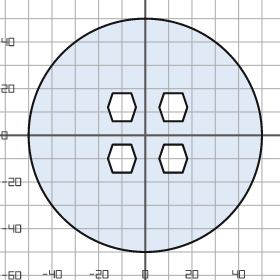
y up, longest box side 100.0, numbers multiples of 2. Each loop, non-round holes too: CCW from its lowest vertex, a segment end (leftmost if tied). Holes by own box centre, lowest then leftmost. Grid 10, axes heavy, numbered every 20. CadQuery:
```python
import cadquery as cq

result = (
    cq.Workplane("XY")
    .moveTo(0.0, 0.0)
    .circle(50.0)
    .moveTo(-14.0, -16.0)
    .lineTo(-6.0, -16.0)
    .lineTo(-4.0, -10.0)
    .lineTo(-6.0, -4.0)
    .lineTo(-14.0, -4.0)
    .lineTo(-16.0, -10.0)
    .close()
    .moveTo(8.0, -16.0)
    .lineTo(16.0, -16.0)
    .lineTo(18.0, -10.0)
    .lineTo(16.0, -4.0)
    .lineTo(8.0, -4.0)
    .lineTo(6.0, -10.0)
    .close()
    .moveTo(-14.0, 6.0)
    .lineTo(-6.0, 6.0)
    .lineTo(-4.0, 12.0)
    .lineTo(-6.0, 18.0)
    .lineTo(-14.0, 18.0)
    .lineTo(-16.0, 12.0)
    .close()
    .moveTo(8.0, 6.0)
    .lineTo(16.0, 6.0)
    .lineTo(18.0, 12.0)
    .lineTo(16.0, 18.0)
    .lineTo(8.0, 18.0)
    .lineTo(6.0, 12.0)
    .close()
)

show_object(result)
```